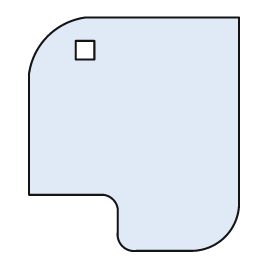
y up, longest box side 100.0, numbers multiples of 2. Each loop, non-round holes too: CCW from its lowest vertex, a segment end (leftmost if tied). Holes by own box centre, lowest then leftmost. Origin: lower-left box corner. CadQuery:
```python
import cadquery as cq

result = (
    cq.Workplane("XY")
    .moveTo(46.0, 0.0)
    .lineTo(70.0, 0.0)
    .threePointArc((84.0, 6.0), (90.0, 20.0))
    .lineTo(90.0, 100.0)
    .lineTo(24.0, 100.0)
    .threePointArc((8.0, 92.0), (0.0, 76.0))
    .lineTo(0.0, 24.0)
    .lineTo(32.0, 24.0)
    .threePointArc((36.0, 22.0), (38.0, 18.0))
    .lineTo(38.0, 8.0)
    .threePointArc((40.0, 2.0), (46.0, 0.0))
    .close()
    .moveTo(20.0, 82.0)
    .lineTo(28.0, 82.0)
    .lineTo(28.0, 90.0)
    .lineTo(20.0, 90.0)
    .close()
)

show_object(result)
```